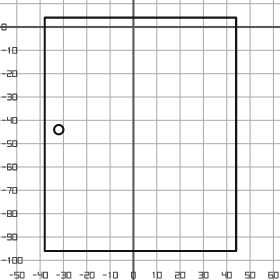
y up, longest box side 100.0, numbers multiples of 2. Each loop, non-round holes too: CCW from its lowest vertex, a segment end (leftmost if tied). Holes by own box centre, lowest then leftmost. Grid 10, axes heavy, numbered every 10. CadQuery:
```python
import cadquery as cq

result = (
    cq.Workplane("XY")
    .moveTo(-38.0, -96.0)
    .lineTo(44.0, -96.0)
    .lineTo(44.0, 4.0)
    .lineTo(-38.0, 4.0)
    .close()
    .moveTo(-32.0, -44.0)
    .circle(2.0)
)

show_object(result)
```